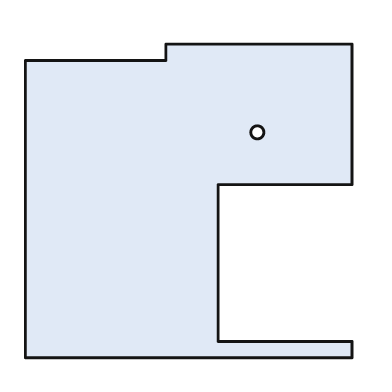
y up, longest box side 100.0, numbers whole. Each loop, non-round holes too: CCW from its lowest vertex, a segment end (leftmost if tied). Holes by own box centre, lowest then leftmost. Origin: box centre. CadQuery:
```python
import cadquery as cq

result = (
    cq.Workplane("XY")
    .moveTo(-50.0, -48.0)
    .lineTo(50.0, -48.0)
    .lineTo(50.0, -43.0)
    .lineTo(9.0, -43.0)
    .lineTo(9.0, 5.0)
    .lineTo(50.0, 5.0)
    .lineTo(50.0, 48.0)
    .lineTo(-7.0, 48.0)
    .lineTo(-7.0, 43.0)
    .lineTo(-50.0, 43.0)
    .close()
    .moveTo(21.0, 21.0)
    .circle(2.0)
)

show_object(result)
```